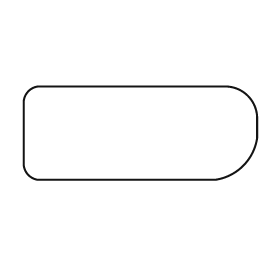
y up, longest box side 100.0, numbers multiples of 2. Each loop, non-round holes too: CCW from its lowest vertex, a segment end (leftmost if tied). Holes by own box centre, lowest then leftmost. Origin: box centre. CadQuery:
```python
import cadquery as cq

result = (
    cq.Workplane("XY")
    .moveTo(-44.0, -20.0)
    .lineTo(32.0, -20.0)
    .threePointArc((44.0, -14.0), (50.0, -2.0))
    .lineTo(50.0, 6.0)
    .threePointArc((46.0, 16.0), (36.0, 20.0))
    .lineTo(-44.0, 20.0)
    .threePointArc((-48.0, 18.0), (-50.0, 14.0))
    .lineTo(-50.0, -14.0)
    .threePointArc((-48.0, -18.0), (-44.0, -20.0))
    .close()
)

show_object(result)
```